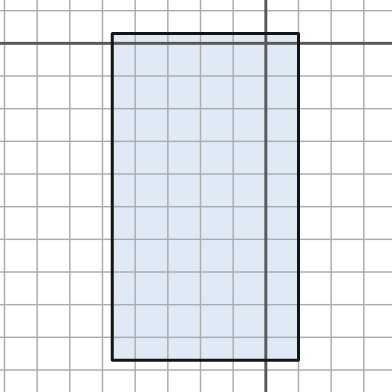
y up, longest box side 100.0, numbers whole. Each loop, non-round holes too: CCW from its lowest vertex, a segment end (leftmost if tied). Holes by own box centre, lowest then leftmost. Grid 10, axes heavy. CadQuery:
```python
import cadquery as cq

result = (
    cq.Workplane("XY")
    .moveTo(-47.0, -97.0)
    .lineTo(10.0, -97.0)
    .lineTo(10.0, 3.0)
    .lineTo(-47.0, 3.0)
    .close()
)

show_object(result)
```